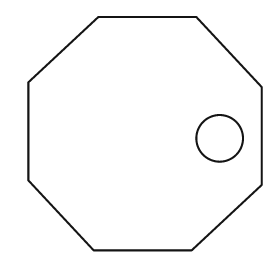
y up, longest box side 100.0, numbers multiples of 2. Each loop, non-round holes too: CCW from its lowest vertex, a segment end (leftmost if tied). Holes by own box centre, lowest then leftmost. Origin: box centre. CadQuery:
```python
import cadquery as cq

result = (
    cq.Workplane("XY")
    .moveTo(-22.0, -50.0)
    .lineTo(20.0, -50.0)
    .lineTo(50.0, -22.0)
    .lineTo(50.0, 20.0)
    .lineTo(22.0, 50.0)
    .lineTo(-20.0, 50.0)
    .lineTo(-50.0, 22.0)
    .lineTo(-50.0, -20.0)
    .close()
    .moveTo(32.0, -2.0)
    .circle(10.0)
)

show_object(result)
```